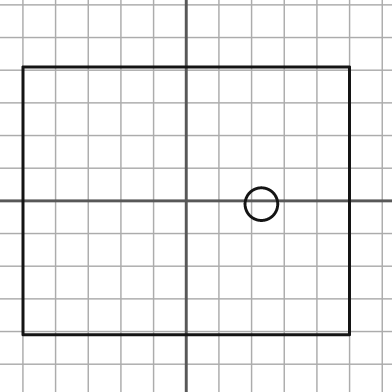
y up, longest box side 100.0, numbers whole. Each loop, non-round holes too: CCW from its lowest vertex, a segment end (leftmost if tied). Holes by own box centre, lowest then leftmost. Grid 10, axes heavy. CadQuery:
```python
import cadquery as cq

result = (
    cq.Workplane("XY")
    .moveTo(-50.0, -41.0)
    .lineTo(50.0, -41.0)
    .lineTo(50.0, 41.0)
    .lineTo(-50.0, 41.0)
    .close()
    .moveTo(23.0, -1.0)
    .circle(5.0)
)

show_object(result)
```